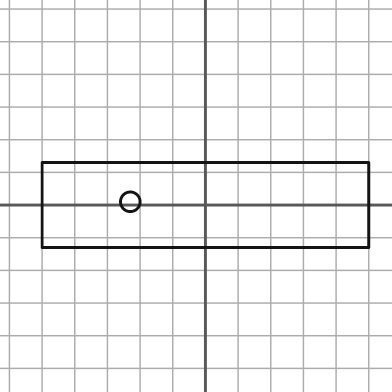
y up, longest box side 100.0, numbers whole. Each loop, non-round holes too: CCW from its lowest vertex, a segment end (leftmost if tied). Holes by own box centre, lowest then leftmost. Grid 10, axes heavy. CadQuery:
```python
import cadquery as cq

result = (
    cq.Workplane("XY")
    .moveTo(-50.0, -13.0)
    .lineTo(50.0, -13.0)
    .lineTo(50.0, 13.0)
    .lineTo(-50.0, 13.0)
    .close()
    .moveTo(-23.0, 1.0)
    .circle(3.0)
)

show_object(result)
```